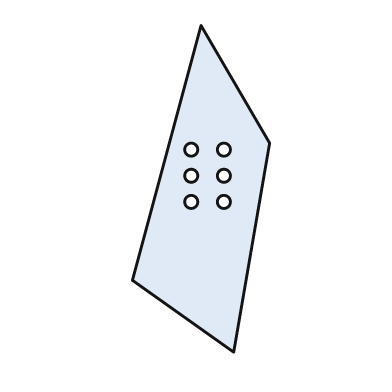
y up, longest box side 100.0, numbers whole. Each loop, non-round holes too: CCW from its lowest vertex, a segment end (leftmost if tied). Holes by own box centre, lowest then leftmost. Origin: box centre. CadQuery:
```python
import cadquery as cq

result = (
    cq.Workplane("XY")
    .moveTo(10.0, -50.0)
    .lineTo(21.0, 14.0)
    .lineTo(0.0, 50.0)
    .lineTo(-21.0, -28.0)
    .close()
    .moveTo(-3.0, -4.0)
    .circle(2.0)
    .moveTo(7.0, -4.0)
    .circle(2.0)
    .moveTo(-3.0, 4.0)
    .circle(2.0)
    .moveTo(7.0, 4.0)
    .circle(2.0)
    .moveTo(-3.0, 12.0)
    .circle(2.0)
    .moveTo(7.0, 12.0)
    .circle(2.0)
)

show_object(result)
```